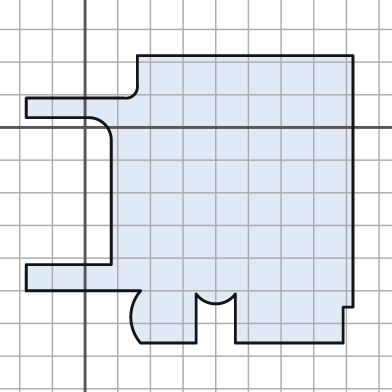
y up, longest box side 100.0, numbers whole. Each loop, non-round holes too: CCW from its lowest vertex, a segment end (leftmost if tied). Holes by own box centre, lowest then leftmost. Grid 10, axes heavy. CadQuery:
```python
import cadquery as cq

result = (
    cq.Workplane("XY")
    .moveTo(17.0, -66.0)
    .lineTo(34.0, -66.0)
    .lineTo(34.0, -51.0)
    .threePointArc((40.0, -54.0), (46.0, -51.0))
    .lineTo(46.0, -66.0)
    .lineTo(79.0, -66.0)
    .lineTo(79.0, -55.0)
    .lineTo(82.0, -55.0)
    .lineTo(82.0, 22.0)
    .lineTo(16.0, 22.0)
    .lineTo(16.0, 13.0)
    .threePointArc((15.0, 10.0), (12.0, 9.0))
    .lineTo(-18.0, 9.0)
    .lineTo(-18.0, 3.0)
    .lineTo(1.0, 3.0)
    .threePointArc((6.0, 1.0), (8.0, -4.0))
    .lineTo(8.0, -42.0)
    .lineTo(-18.0, -42.0)
    .lineTo(-18.0, -50.0)
    .lineTo(17.0, -50.0)
    .threePointArc((14.0, -58.0), (17.0, -66.0))
    .close()
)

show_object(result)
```